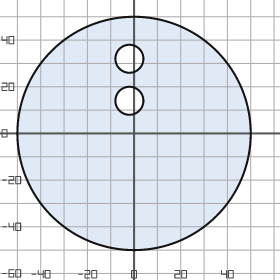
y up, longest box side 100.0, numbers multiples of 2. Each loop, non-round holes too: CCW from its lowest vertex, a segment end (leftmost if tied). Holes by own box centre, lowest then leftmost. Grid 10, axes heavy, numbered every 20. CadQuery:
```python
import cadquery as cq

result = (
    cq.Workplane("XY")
    .moveTo(0.0, 0.0)
    .circle(50.0)
    .moveTo(-2.0, 14.0)
    .circle(6.0)
    .moveTo(-2.0, 32.0)
    .circle(6.0)
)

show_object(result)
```